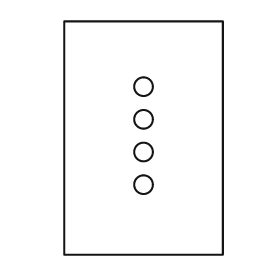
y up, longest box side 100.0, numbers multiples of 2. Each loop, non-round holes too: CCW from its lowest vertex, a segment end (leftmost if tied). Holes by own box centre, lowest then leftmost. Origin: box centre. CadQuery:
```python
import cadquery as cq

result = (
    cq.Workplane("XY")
    .moveTo(-34.0, -50.0)
    .lineTo(34.0, -50.0)
    .lineTo(34.0, 50.0)
    .lineTo(-34.0, 50.0)
    .close()
    .moveTo(0.0, -20.0)
    .circle(4.0)
    .moveTo(0.0, -6.0)
    .circle(4.0)
    .moveTo(0.0, 8.0)
    .circle(4.0)
    .moveTo(0.0, 22.0)
    .circle(4.0)
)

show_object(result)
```